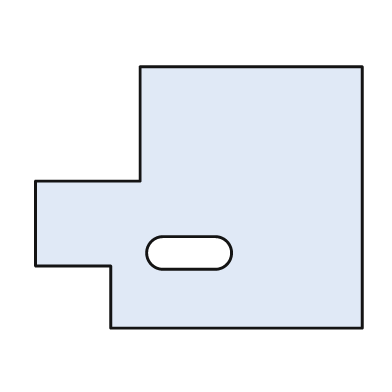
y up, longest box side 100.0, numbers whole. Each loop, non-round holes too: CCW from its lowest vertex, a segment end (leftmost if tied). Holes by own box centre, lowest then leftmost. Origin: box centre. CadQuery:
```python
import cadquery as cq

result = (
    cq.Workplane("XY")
    .moveTo(-27.0, -40.0)
    .lineTo(50.0, -40.0)
    .lineTo(50.0, 40.0)
    .lineTo(-18.0, 40.0)
    .lineTo(-18.0, 5.0)
    .lineTo(-50.0, 5.0)
    .lineTo(-50.0, -21.0)
    .lineTo(-27.0, -21.0)
    .close()
    .moveTo(-11.0, -22.0)
    .lineTo(5.0, -22.0)
    .threePointArc((10.0, -17.0), (5.0, -12.0))
    .lineTo(-11.0, -12.0)
    .threePointArc((-16.0, -17.0), (-11.0, -22.0))
    .close()
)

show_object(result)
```